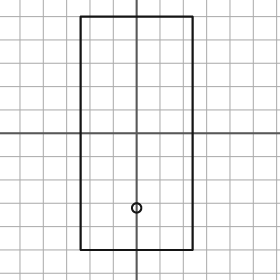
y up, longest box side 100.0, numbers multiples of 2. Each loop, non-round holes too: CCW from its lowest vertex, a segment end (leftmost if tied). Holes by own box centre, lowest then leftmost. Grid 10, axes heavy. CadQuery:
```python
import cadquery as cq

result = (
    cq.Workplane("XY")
    .moveTo(-24.0, -50.0)
    .lineTo(24.0, -50.0)
    .lineTo(24.0, 50.0)
    .lineTo(-24.0, 50.0)
    .close()
    .moveTo(0.0, -32.0)
    .circle(2.0)
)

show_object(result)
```